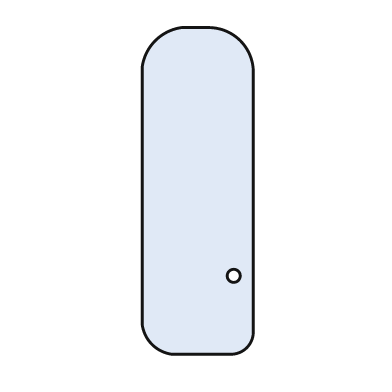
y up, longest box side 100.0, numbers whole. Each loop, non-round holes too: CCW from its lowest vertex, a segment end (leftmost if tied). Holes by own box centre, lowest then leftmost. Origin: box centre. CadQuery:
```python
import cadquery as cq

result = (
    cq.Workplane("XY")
    .moveTo(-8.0, -50.0)
    .lineTo(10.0, -50.0)
    .threePointArc((15.0, -48.0), (17.0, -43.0))
    .lineTo(17.0, 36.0)
    .threePointArc((13.0, 46.0), (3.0, 50.0))
    .lineTo(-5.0, 50.0)
    .threePointArc((-13.0, 46.0), (-17.0, 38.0))
    .lineTo(-17.0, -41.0)
    .threePointArc((-14.0, -47.0), (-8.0, -50.0))
    .close()
    .moveTo(11.0, -26.0)
    .circle(2.0)
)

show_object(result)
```